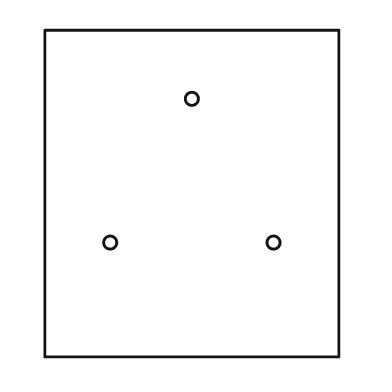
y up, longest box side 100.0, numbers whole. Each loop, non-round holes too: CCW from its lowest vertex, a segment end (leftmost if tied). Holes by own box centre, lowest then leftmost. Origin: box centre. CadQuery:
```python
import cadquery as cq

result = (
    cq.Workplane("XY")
    .moveTo(-45.0, -50.0)
    .lineTo(45.0, -50.0)
    .lineTo(45.0, 50.0)
    .lineTo(-45.0, 50.0)
    .close()
    .moveTo(-25.0, -15.0)
    .circle(2.0)
    .moveTo(25.0, -15.0)
    .circle(2.0)
    .moveTo(0.0, 29.0)
    .circle(2.0)
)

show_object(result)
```